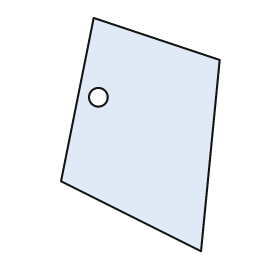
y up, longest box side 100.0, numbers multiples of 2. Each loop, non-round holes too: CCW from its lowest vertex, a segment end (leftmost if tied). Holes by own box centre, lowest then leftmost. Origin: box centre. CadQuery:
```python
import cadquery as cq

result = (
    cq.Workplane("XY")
    .moveTo(26.0, -50.0)
    .lineTo(34.0, 32.0)
    .lineTo(-20.0, 50.0)
    .lineTo(-34.0, -20.0)
    .close()
    .moveTo(-18.0, 16.0)
    .circle(4.0)
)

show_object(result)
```